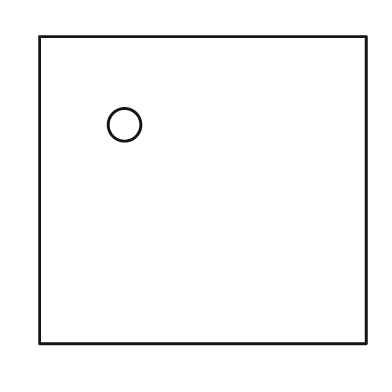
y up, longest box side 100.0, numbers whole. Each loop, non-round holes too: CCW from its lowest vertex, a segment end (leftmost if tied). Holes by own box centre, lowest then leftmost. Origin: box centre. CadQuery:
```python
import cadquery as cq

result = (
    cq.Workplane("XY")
    .moveTo(-50.0, -47.0)
    .lineTo(50.0, -47.0)
    .lineTo(50.0, 47.0)
    .lineTo(-50.0, 47.0)
    .close()
    .moveTo(-24.0, 20.0)
    .circle(5.0)
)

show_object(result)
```